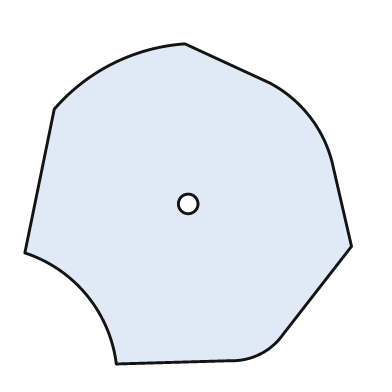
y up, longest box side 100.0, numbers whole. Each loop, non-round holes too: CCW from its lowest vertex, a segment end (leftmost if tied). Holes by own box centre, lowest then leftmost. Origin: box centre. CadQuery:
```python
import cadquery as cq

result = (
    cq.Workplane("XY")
    .moveTo(-22.0, -49.0)
    .lineTo(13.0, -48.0)
    .threePointArc((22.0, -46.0), (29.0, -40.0))
    .lineTo(50.0, -13.0)
    .lineTo(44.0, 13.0)
    .threePointArc((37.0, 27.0), (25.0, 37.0))
    .lineTo(-1.0, 49.0)
    .threePointArc((-23.0, 43.0), (-41.0, 29.0))
    .lineTo(-50.0, -15.0)
    .threePointArc((-31.0, -28.0), (-22.0, -49.0))
    .close()
    .moveTo(0.0, 0.0)
    .circle(3.0)
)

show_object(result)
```